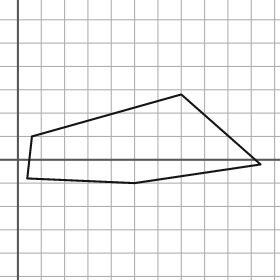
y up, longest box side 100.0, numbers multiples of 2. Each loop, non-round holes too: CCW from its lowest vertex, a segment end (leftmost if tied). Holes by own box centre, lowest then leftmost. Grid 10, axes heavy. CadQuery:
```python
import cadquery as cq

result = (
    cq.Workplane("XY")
    .moveTo(50.0, -10.0)
    .lineTo(104.0, -2.0)
    .lineTo(70.0, 28.0)
    .lineTo(6.0, 10.0)
    .lineTo(4.0, -8.0)
    .close()
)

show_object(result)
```